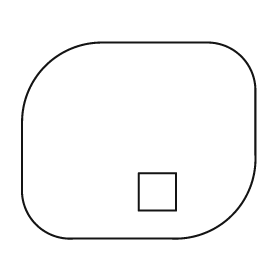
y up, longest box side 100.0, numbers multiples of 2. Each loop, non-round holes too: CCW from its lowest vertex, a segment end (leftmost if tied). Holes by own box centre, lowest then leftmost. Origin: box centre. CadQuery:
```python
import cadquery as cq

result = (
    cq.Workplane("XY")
    .moveTo(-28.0, -42.0)
    .lineTo(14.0, -42.0)
    .threePointArc((40.0, -32.0), (50.0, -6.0))
    .lineTo(50.0, 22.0)
    .threePointArc((44.0, 36.0), (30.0, 42.0))
    .lineTo(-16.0, 42.0)
    .threePointArc((-40.0, 32.0), (-50.0, 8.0))
    .lineTo(-50.0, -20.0)
    .threePointArc((-44.0, -36.0), (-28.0, -42.0))
    .close()
    .moveTo(0.0, -30.0)
    .lineTo(16.0, -30.0)
    .lineTo(16.0, -14.0)
    .lineTo(0.0, -14.0)
    .close()
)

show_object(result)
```